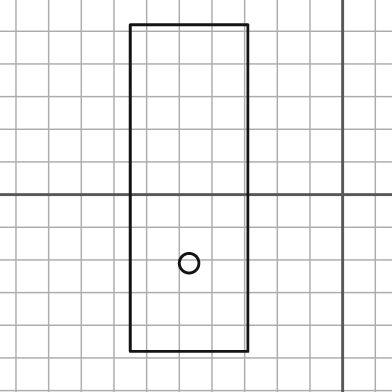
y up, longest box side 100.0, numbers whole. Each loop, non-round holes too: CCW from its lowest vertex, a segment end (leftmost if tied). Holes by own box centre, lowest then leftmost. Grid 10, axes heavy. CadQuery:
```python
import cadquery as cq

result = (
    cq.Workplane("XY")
    .moveTo(-65.0, -48.0)
    .lineTo(-29.0, -48.0)
    .lineTo(-29.0, 52.0)
    .lineTo(-65.0, 52.0)
    .close()
    .moveTo(-47.0, -21.0)
    .circle(3.0)
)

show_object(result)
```